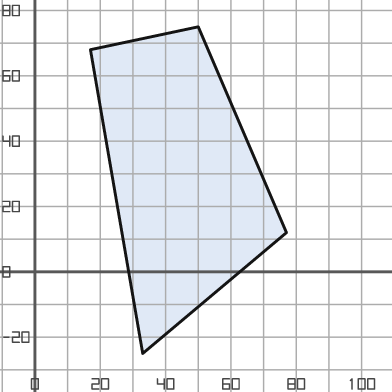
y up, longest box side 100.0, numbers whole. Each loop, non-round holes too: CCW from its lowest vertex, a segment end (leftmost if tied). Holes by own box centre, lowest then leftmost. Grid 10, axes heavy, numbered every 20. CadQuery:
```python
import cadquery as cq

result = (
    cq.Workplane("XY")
    .moveTo(33.0, -25.0)
    .lineTo(77.0, 12.0)
    .lineTo(50.0, 75.0)
    .lineTo(17.0, 68.0)
    .close()
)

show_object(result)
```